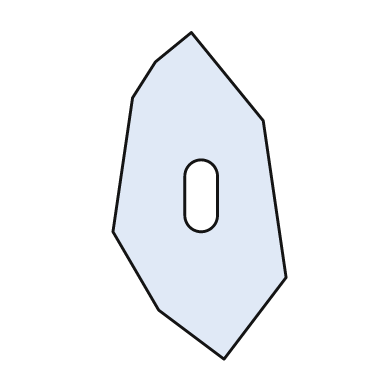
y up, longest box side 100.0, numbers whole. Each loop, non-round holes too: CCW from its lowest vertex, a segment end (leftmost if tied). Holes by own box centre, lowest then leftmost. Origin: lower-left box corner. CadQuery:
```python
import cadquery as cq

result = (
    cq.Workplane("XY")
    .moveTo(34.0, 0.0)
    .lineTo(53.0, 25.0)
    .lineTo(46.0, 73.0)
    .lineTo(24.0, 100.0)
    .lineTo(13.0, 91.0)
    .lineTo(6.0, 80.0)
    .lineTo(0.0, 39.0)
    .lineTo(14.0, 15.0)
    .close()
    .moveTo(22.0, 44.0)
    .threePointArc((27.0, 39.0), (32.0, 44.0))
    .lineTo(32.0, 56.0)
    .threePointArc((27.0, 61.0), (22.0, 56.0))
    .close()
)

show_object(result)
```